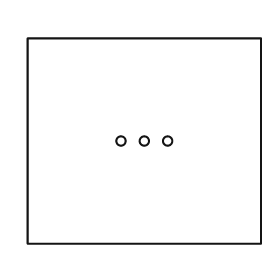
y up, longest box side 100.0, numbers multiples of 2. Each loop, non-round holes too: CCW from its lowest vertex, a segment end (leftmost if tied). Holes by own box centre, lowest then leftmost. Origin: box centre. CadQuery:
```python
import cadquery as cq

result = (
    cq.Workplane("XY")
    .moveTo(-50.0, -44.0)
    .lineTo(50.0, -44.0)
    .lineTo(50.0, 44.0)
    .lineTo(-50.0, 44.0)
    .close()
    .moveTo(-10.0, 0.0)
    .circle(2.0)
    .moveTo(0.0, 0.0)
    .circle(2.0)
    .moveTo(10.0, 0.0)
    .circle(2.0)
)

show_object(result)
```